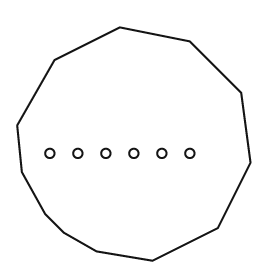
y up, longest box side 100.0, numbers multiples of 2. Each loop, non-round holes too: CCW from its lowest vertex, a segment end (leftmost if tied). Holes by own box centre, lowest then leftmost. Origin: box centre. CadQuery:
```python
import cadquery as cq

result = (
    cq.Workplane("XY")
    .moveTo(8.0, -50.0)
    .lineTo(36.0, -36.0)
    .lineTo(50.0, -8.0)
    .lineTo(46.0, 22.0)
    .lineTo(24.0, 44.0)
    .lineTo(-6.0, 50.0)
    .lineTo(-34.0, 36.0)
    .lineTo(-50.0, 8.0)
    .lineTo(-48.0, -12.0)
    .lineTo(-38.0, -30.0)
    .lineTo(-30.0, -38.0)
    .lineTo(-16.0, -46.0)
    .close()
    .moveTo(-36.0, -4.0)
    .circle(2.0)
    .moveTo(-24.0, -4.0)
    .circle(2.0)
    .moveTo(-12.0, -4.0)
    .circle(2.0)
    .moveTo(0.0, -4.0)
    .circle(2.0)
    .moveTo(12.0, -4.0)
    .circle(2.0)
    .moveTo(24.0, -4.0)
    .circle(2.0)
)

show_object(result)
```